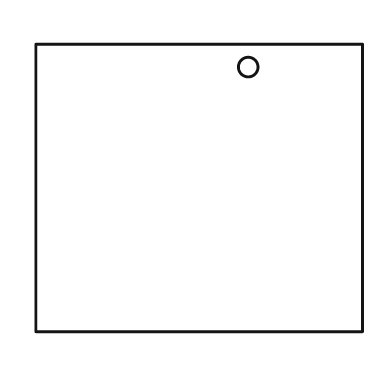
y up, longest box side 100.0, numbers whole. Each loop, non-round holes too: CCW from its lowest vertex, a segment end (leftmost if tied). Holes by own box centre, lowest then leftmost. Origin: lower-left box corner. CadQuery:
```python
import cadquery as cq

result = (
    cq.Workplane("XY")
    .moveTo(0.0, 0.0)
    .lineTo(100.0, 0.0)
    .lineTo(100.0, 88.0)
    .lineTo(0.0, 88.0)
    .close()
    .moveTo(65.0, 81.0)
    .circle(3.0)
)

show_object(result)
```